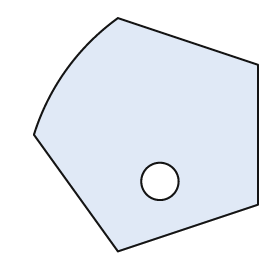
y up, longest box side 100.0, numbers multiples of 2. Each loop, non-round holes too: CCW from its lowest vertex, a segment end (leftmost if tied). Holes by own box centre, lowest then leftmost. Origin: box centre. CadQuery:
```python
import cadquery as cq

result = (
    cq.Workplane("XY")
    .moveTo(-12.0, -50.0)
    .lineTo(48.0, -30.0)
    .lineTo(48.0, 30.0)
    .lineTo(-12.0, 50.0)
    .threePointArc((-34.0, 28.0), (-48.0, 0.0))
    .close()
    .moveTo(6.0, -20.0)
    .circle(8.0)
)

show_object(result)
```